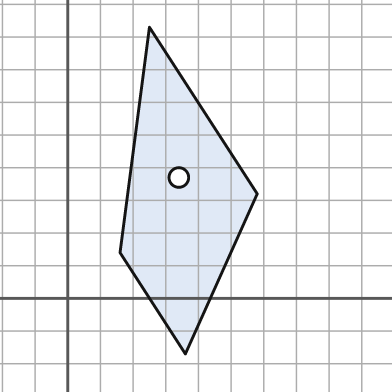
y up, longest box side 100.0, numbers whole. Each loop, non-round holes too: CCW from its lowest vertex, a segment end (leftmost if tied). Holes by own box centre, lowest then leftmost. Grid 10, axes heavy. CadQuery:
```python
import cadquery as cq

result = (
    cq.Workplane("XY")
    .moveTo(36.0, -17.0)
    .lineTo(58.0, 32.0)
    .lineTo(25.0, 83.0)
    .lineTo(16.0, 14.0)
    .close()
    .moveTo(34.0, 37.0)
    .circle(3.0)
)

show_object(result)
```